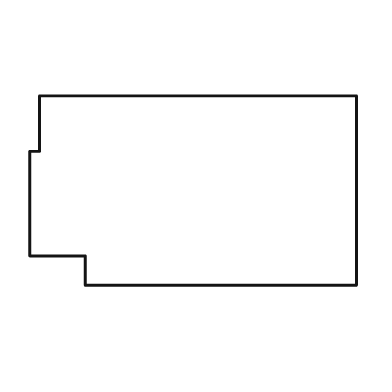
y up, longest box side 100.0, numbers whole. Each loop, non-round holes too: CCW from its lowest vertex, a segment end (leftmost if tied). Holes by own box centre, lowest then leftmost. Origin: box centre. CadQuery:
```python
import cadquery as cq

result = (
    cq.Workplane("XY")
    .moveTo(-33.0, -29.0)
    .lineTo(50.0, -29.0)
    .lineTo(50.0, 29.0)
    .lineTo(-47.0, 29.0)
    .lineTo(-47.0, 12.0)
    .lineTo(-50.0, 12.0)
    .lineTo(-50.0, -20.0)
    .lineTo(-33.0, -20.0)
    .close()
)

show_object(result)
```